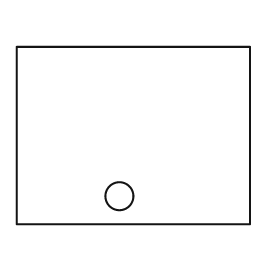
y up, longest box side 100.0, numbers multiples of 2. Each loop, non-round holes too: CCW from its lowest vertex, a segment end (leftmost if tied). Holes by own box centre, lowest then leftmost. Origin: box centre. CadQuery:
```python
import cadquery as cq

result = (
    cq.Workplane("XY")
    .moveTo(-50.0, -38.0)
    .lineTo(50.0, -38.0)
    .lineTo(50.0, 38.0)
    .lineTo(-50.0, 38.0)
    .close()
    .moveTo(-6.0, -26.0)
    .circle(6.0)
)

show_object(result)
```